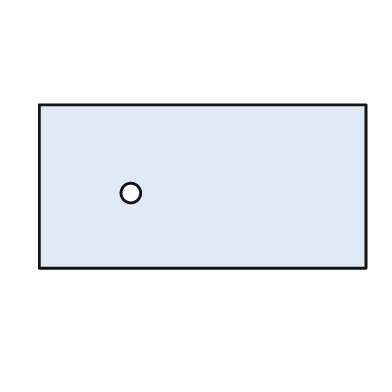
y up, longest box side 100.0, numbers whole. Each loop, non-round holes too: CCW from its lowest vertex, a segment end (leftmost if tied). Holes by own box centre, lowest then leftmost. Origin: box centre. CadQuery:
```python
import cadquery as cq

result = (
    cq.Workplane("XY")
    .moveTo(-50.0, -25.0)
    .lineTo(50.0, -25.0)
    .lineTo(50.0, 25.0)
    .lineTo(-50.0, 25.0)
    .close()
    .moveTo(-22.0, -2.0)
    .circle(3.0)
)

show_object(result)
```